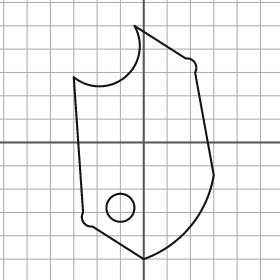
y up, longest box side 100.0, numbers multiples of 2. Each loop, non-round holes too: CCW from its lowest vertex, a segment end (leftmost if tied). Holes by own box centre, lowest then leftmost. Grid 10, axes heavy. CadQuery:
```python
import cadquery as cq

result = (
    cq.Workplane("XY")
    .moveTo(0.0, -50.0)
    .threePointArc((20.0, -36.0), (30.0, -14.0))
    .lineTo(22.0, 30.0)
    .threePointArc((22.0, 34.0), (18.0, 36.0))
    .lineTo(-4.0, 50.0)
    .threePointArc((-8.0, 28.0), (-30.0, 28.0))
    .lineTo(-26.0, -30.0)
    .threePointArc((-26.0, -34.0), (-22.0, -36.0))
    .close()
    .moveTo(-10.0, -28.0)
    .circle(6.0)
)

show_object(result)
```